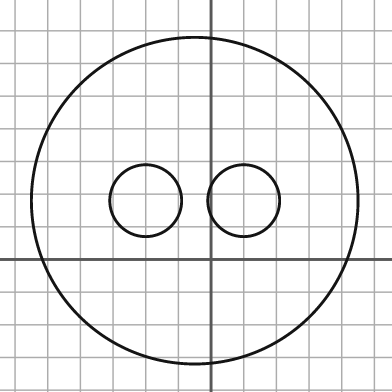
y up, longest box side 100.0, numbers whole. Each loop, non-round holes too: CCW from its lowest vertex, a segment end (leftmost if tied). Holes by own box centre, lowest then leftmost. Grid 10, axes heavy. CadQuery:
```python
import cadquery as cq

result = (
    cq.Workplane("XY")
    .moveTo(-5.0, 18.0)
    .circle(50.0)
    .moveTo(-20.0, 18.0)
    .circle(11.0)
    .moveTo(10.0, 18.0)
    .circle(11.0)
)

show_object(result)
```